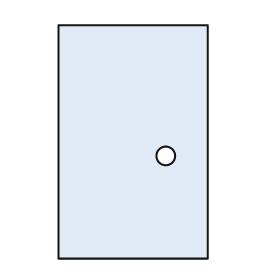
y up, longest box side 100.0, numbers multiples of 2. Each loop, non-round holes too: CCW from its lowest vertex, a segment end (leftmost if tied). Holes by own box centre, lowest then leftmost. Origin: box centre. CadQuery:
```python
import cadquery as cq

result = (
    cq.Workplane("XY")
    .moveTo(-32.0, -50.0)
    .lineTo(32.0, -50.0)
    .lineTo(32.0, 50.0)
    .lineTo(-32.0, 50.0)
    .close()
    .moveTo(14.0, -6.0)
    .circle(4.0)
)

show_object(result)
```